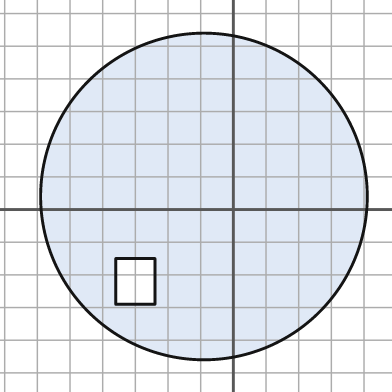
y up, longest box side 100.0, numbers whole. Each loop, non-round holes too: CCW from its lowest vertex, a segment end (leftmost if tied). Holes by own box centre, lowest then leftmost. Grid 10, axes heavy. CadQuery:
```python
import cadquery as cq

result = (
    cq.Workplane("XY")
    .moveTo(-9.0, 4.0)
    .circle(50.0)
    .moveTo(-36.0, -29.0)
    .lineTo(-24.0, -29.0)
    .lineTo(-24.0, -15.0)
    .lineTo(-36.0, -15.0)
    .close()
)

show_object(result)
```